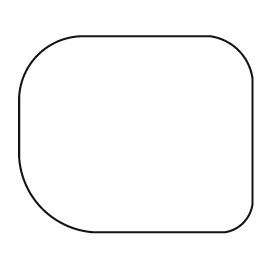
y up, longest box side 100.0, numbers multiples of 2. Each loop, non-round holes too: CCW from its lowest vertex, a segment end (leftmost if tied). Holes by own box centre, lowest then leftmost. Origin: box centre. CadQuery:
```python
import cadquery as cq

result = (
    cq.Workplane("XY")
    .moveTo(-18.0, -42.0)
    .lineTo(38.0, -42.0)
    .threePointArc((46.0, -38.0), (50.0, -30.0))
    .lineTo(50.0, 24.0)
    .threePointArc((44.0, 36.0), (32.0, 42.0))
    .lineTo(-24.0, 42.0)
    .threePointArc((-42.0, 34.0), (-50.0, 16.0))
    .lineTo(-50.0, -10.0)
    .threePointArc((-40.0, -32.0), (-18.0, -42.0))
    .close()
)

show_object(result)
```